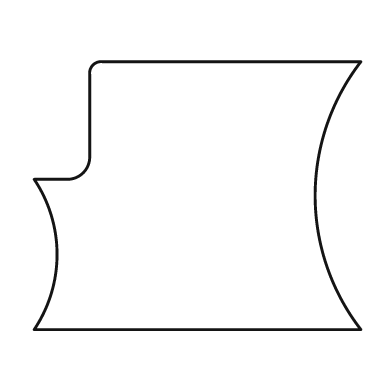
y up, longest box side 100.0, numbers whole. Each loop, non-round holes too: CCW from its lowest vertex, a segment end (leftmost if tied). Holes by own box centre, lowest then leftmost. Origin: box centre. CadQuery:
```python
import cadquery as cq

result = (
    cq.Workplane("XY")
    .moveTo(-50.0, -41.0)
    .lineTo(50.0, -41.0)
    .threePointArc((36.0, 0.0), (50.0, 41.0))
    .lineTo(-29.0, 41.0)
    .threePointArc((-32.0, 40.0), (-33.0, 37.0))
    .lineTo(-33.0, 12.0)
    .threePointArc((-35.0, 7.0), (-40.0, 5.0))
    .lineTo(-50.0, 5.0)
    .threePointArc((-43.0, -18.0), (-50.0, -41.0))
    .close()
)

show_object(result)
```